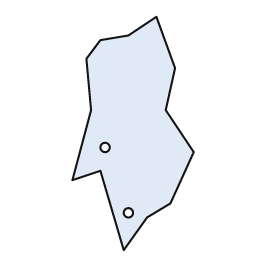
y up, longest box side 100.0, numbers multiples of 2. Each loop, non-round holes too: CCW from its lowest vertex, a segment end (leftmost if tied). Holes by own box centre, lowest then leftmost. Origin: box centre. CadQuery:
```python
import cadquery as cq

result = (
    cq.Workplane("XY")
    .moveTo(-4.0, -50.0)
    .lineTo(6.0, -36.0)
    .lineTo(16.0, -30.0)
    .lineTo(26.0, -8.0)
    .lineTo(14.0, 10.0)
    .lineTo(18.0, 28.0)
    .lineTo(10.0, 50.0)
    .lineTo(-2.0, 42.0)
    .lineTo(-14.0, 40.0)
    .lineTo(-20.0, 32.0)
    .lineTo(-18.0, 10.0)
    .lineTo(-26.0, -20.0)
    .lineTo(-14.0, -16.0)
    .close()
    .moveTo(-2.0, -34.0)
    .circle(2.0)
    .moveTo(-12.0, -6.0)
    .circle(2.0)
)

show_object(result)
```